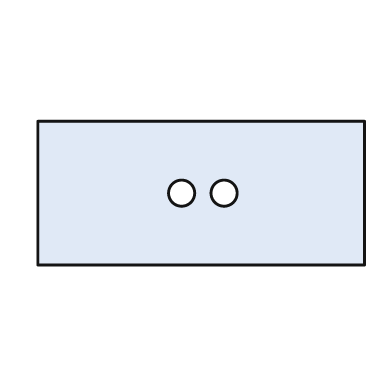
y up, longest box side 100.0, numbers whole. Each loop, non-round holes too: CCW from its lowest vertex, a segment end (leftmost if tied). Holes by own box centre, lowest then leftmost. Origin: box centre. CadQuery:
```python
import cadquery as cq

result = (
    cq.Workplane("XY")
    .moveTo(-50.0, -22.0)
    .lineTo(50.0, -22.0)
    .lineTo(50.0, 22.0)
    .lineTo(-50.0, 22.0)
    .close()
    .moveTo(-6.0, 0.0)
    .circle(4.0)
    .moveTo(7.0, 0.0)
    .circle(4.0)
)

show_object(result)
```